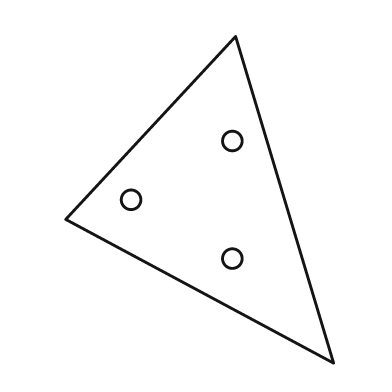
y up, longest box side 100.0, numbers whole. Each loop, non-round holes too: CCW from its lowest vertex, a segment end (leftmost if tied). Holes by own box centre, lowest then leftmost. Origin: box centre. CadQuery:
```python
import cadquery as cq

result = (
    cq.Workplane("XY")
    .moveTo(41.0, -50.0)
    .lineTo(11.0, 50.0)
    .lineTo(-41.0, -6.0)
    .close()
    .moveTo(10.0, -18.0)
    .circle(3.0)
    .moveTo(-21.0, 0.0)
    .circle(3.0)
    .moveTo(10.0, 18.0)
    .circle(3.0)
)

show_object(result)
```